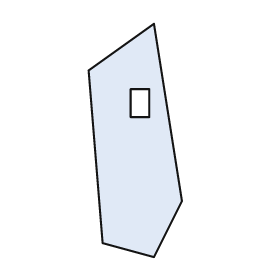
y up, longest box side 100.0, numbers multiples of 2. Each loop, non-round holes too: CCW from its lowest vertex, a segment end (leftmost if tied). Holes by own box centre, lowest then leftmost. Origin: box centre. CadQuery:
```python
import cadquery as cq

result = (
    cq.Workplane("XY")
    .moveTo(8.0, -50.0)
    .lineTo(20.0, -26.0)
    .lineTo(8.0, 50.0)
    .lineTo(-20.0, 30.0)
    .lineTo(-14.0, -44.0)
    .close()
    .moveTo(-2.0, 10.0)
    .lineTo(6.0, 10.0)
    .lineTo(6.0, 22.0)
    .lineTo(-2.0, 22.0)
    .close()
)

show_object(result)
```